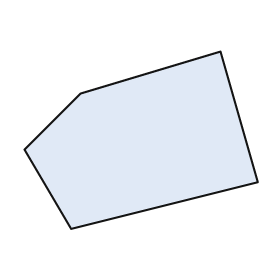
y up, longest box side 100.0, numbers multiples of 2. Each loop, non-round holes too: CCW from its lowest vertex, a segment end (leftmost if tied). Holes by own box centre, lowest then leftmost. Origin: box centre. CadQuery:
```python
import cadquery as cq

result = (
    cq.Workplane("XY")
    .moveTo(-30.0, -38.0)
    .lineTo(50.0, -18.0)
    .lineTo(34.0, 38.0)
    .lineTo(-26.0, 20.0)
    .lineTo(-50.0, -4.0)
    .close()
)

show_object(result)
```